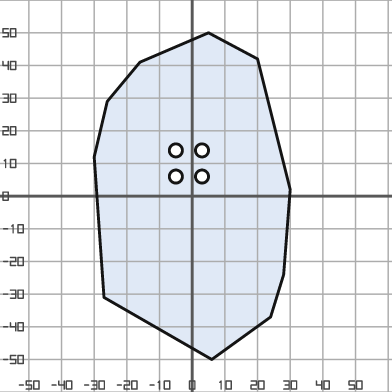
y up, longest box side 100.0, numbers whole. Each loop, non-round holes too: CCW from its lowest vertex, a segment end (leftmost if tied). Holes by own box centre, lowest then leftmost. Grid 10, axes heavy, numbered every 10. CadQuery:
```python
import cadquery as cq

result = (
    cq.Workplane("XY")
    .moveTo(6.0, -50.0)
    .lineTo(24.0, -37.0)
    .lineTo(28.0, -24.0)
    .lineTo(30.0, 2.0)
    .lineTo(20.0, 42.0)
    .lineTo(5.0, 50.0)
    .lineTo(-16.0, 41.0)
    .lineTo(-26.0, 29.0)
    .lineTo(-30.0, 12.0)
    .lineTo(-27.0, -31.0)
    .close()
    .moveTo(-5.0, 6.0)
    .circle(2.0)
    .moveTo(3.0, 6.0)
    .circle(2.0)
    .moveTo(-5.0, 14.0)
    .circle(2.0)
    .moveTo(3.0, 14.0)
    .circle(2.0)
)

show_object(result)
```